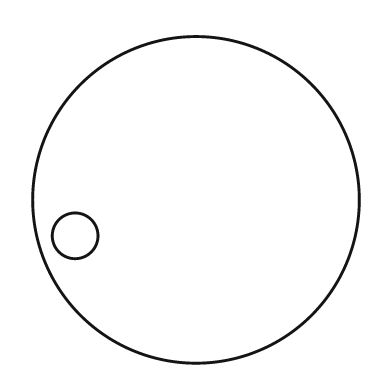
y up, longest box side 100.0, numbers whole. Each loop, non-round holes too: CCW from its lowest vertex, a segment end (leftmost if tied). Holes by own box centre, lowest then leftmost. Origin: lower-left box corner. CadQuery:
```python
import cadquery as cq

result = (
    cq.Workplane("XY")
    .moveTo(50.0, 50.0)
    .circle(50.0)
    .moveTo(13.0, 39.0)
    .circle(7.0)
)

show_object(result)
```